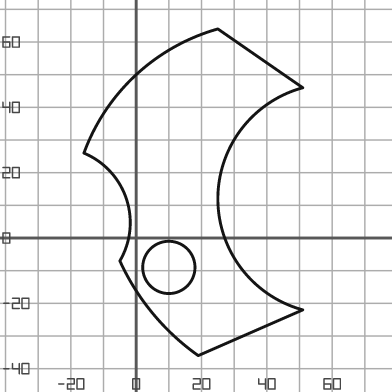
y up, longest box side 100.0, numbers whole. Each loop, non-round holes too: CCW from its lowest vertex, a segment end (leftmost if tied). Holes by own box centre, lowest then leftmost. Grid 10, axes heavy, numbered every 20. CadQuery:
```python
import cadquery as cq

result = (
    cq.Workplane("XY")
    .moveTo(19.0, -36.0)
    .lineTo(51.0, -22.0)
    .threePointArc((25.0, 12.0), (51.0, 46.0))
    .lineTo(25.0, 64.0)
    .threePointArc((0.0, 50.0), (-16.0, 26.0))
    .threePointArc((-3.0, 12.0), (-5.0, -7.0))
    .threePointArc((5.0, -23.0), (19.0, -36.0))
    .close()
    .moveTo(10.0, -9.0)
    .circle(8.0)
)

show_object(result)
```